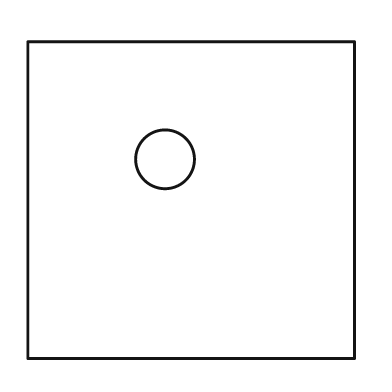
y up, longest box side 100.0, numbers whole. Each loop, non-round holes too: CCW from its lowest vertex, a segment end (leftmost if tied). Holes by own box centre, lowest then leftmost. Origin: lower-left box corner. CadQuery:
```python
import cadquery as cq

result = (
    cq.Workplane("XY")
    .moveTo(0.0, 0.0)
    .lineTo(100.0, 0.0)
    .lineTo(100.0, 97.0)
    .lineTo(0.0, 97.0)
    .close()
    .moveTo(42.0, 61.0)
    .circle(9.0)
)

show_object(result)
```